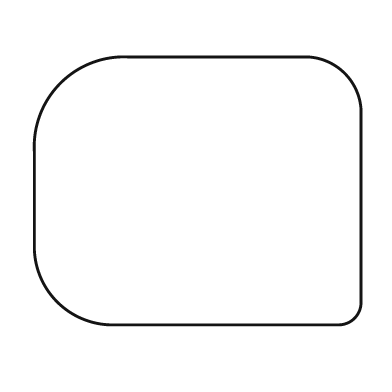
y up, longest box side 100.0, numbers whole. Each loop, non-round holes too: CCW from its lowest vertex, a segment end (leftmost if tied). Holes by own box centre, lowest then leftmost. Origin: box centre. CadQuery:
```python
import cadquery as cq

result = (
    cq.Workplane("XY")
    .moveTo(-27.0, -41.0)
    .lineTo(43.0, -41.0)
    .threePointArc((48.0, -39.0), (50.0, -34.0))
    .lineTo(50.0, 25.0)
    .threePointArc((45.0, 36.0), (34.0, 41.0))
    .lineTo(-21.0, 41.0)
    .threePointArc((-42.0, 33.0), (-50.0, 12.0))
    .lineTo(-50.0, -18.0)
    .threePointArc((-43.0, -34.0), (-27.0, -41.0))
    .close()
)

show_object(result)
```